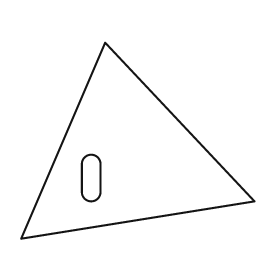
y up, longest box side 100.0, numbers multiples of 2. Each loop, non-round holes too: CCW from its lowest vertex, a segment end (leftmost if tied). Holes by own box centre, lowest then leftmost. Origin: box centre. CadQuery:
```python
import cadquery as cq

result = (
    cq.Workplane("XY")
    .moveTo(-50.0, -42.0)
    .lineTo(50.0, -26.0)
    .lineTo(-14.0, 42.0)
    .close()
    .moveTo(-24.0, -22.0)
    .threePointArc((-20.0, -26.0), (-16.0, -22.0))
    .lineTo(-16.0, -10.0)
    .threePointArc((-20.0, -6.0), (-24.0, -10.0))
    .close()
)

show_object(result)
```